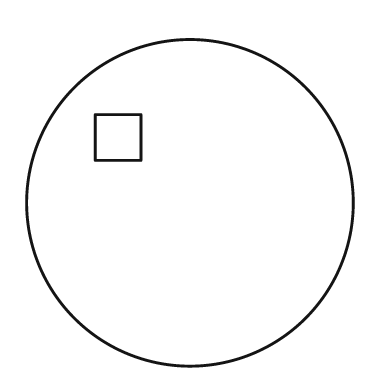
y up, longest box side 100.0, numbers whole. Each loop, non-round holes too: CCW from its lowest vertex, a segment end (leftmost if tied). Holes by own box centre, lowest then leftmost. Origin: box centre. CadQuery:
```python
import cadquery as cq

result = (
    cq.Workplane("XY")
    .moveTo(0.0, 0.0)
    .circle(50.0)
    .moveTo(-29.0, 13.0)
    .lineTo(-15.0, 13.0)
    .lineTo(-15.0, 27.0)
    .lineTo(-29.0, 27.0)
    .close()
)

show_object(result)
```